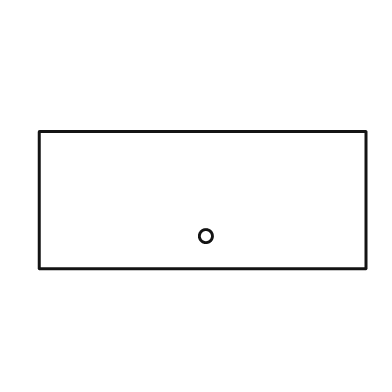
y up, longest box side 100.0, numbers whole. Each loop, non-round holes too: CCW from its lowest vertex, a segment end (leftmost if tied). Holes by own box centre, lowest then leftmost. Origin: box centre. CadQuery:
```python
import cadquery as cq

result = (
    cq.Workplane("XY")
    .moveTo(-50.0, -21.0)
    .lineTo(50.0, -21.0)
    .lineTo(50.0, 21.0)
    .lineTo(-50.0, 21.0)
    .close()
    .moveTo(1.0, -11.0)
    .circle(2.0)
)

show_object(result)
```